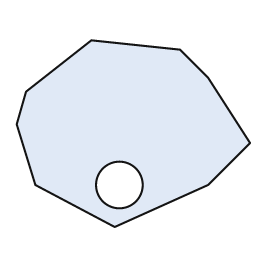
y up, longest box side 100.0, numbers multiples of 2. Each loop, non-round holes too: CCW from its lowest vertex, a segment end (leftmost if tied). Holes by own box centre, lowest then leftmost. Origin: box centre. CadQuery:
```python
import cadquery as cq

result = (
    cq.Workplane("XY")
    .moveTo(-8.0, -40.0)
    .lineTo(32.0, -22.0)
    .lineTo(50.0, -4.0)
    .lineTo(32.0, 24.0)
    .lineTo(20.0, 36.0)
    .lineTo(-18.0, 40.0)
    .lineTo(-46.0, 18.0)
    .lineTo(-50.0, 4.0)
    .lineTo(-42.0, -22.0)
    .close()
    .moveTo(-6.0, -22.0)
    .circle(10.0)
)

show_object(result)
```